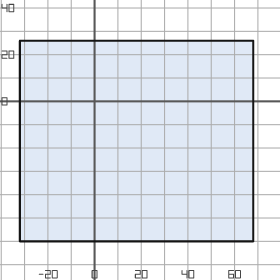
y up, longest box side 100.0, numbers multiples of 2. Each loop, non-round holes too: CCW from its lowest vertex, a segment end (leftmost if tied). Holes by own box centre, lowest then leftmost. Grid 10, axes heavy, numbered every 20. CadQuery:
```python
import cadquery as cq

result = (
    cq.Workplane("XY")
    .moveTo(-32.0, -60.0)
    .lineTo(68.0, -60.0)
    .lineTo(68.0, 26.0)
    .lineTo(-32.0, 26.0)
    .close()
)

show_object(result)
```